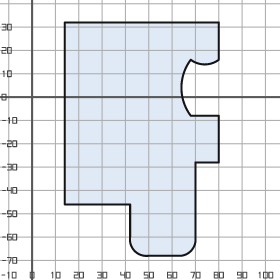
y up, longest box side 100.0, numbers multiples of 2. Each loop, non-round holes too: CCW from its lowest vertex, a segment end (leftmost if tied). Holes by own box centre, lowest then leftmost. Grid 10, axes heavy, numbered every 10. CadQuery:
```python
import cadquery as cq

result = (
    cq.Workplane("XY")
    .moveTo(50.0, -68.0)
    .lineTo(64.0, -68.0)
    .threePointArc((68.0, -66.0), (70.0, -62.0))
    .lineTo(70.0, -28.0)
    .lineTo(80.0, -28.0)
    .lineTo(80.0, -8.0)
    .lineTo(68.0, -8.0)
    .threePointArc((64.0, 4.0), (68.0, 16.0))
    .threePointArc((74.0, 14.0), (80.0, 16.0))
    .lineTo(80.0, 32.0)
    .lineTo(14.0, 32.0)
    .lineTo(14.0, -46.0)
    .lineTo(42.0, -46.0)
    .lineTo(42.0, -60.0)
    .threePointArc((44.0, -66.0), (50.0, -68.0))
    .close()
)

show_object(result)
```